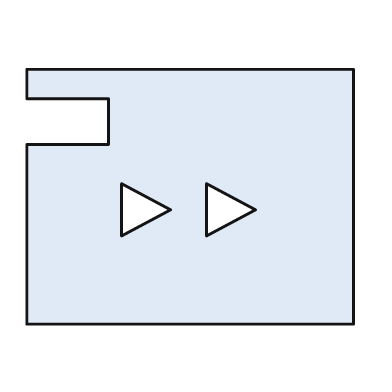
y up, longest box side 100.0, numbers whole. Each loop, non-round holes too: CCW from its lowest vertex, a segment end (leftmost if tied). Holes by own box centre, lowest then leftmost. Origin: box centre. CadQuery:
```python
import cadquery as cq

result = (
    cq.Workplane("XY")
    .moveTo(-50.0, -39.0)
    .lineTo(50.0, -39.0)
    .lineTo(50.0, 39.0)
    .lineTo(-50.0, 39.0)
    .lineTo(-50.0, 30.0)
    .lineTo(-25.0, 30.0)
    .lineTo(-25.0, 16.0)
    .lineTo(-50.0, 16.0)
    .close()
    .moveTo(-21.0, -12.0)
    .lineTo(-6.0, -4.0)
    .lineTo(-21.0, 4.0)
    .close()
    .moveTo(5.0, -12.0)
    .lineTo(20.0, -4.0)
    .lineTo(5.0, 4.0)
    .close()
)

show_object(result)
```